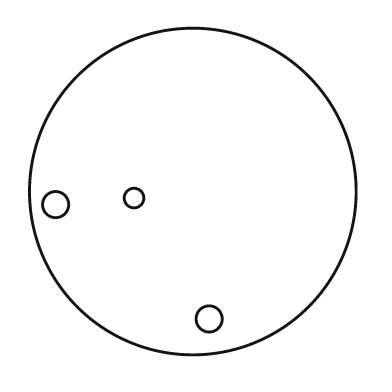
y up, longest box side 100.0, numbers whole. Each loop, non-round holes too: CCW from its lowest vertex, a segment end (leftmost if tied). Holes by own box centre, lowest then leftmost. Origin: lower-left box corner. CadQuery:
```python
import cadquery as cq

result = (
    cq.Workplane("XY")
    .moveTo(50.0, 50.0)
    .circle(50.0)
    .moveTo(55.0, 11.0)
    .circle(4.0)
    .moveTo(8.0, 46.0)
    .circle(4.0)
    .moveTo(32.0, 48.0)
    .circle(3.0)
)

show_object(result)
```